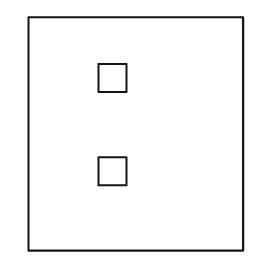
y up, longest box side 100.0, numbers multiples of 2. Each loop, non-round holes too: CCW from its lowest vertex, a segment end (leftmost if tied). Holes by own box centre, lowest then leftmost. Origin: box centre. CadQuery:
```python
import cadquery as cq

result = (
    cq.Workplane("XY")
    .moveTo(-46.0, -50.0)
    .lineTo(46.0, -50.0)
    .lineTo(46.0, 50.0)
    .lineTo(-46.0, 50.0)
    .close()
    .moveTo(-16.0, -22.0)
    .lineTo(-4.0, -22.0)
    .lineTo(-4.0, -10.0)
    .lineTo(-16.0, -10.0)
    .close()
    .moveTo(-16.0, 18.0)
    .lineTo(-4.0, 18.0)
    .lineTo(-4.0, 30.0)
    .lineTo(-16.0, 30.0)
    .close()
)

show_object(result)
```